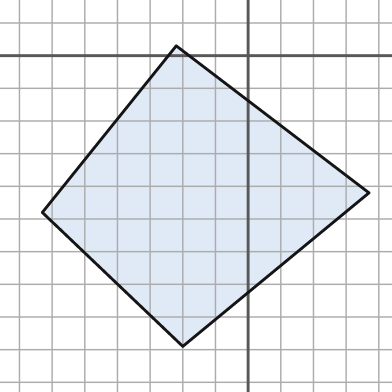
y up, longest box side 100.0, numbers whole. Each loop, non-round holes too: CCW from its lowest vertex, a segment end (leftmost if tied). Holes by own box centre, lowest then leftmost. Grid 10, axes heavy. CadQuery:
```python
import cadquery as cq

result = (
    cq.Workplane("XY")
    .moveTo(-20.0, -89.0)
    .lineTo(37.0, -42.0)
    .lineTo(-22.0, 3.0)
    .lineTo(-63.0, -48.0)
    .close()
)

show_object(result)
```